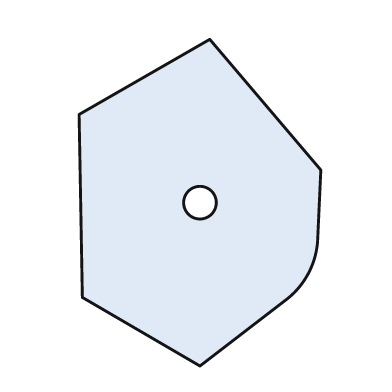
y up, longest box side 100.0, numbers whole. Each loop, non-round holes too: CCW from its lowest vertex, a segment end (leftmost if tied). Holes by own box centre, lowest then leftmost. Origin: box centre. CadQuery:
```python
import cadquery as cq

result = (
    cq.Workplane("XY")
    .moveTo(0.0, -50.0)
    .lineTo(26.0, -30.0)
    .threePointArc((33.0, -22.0), (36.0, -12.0))
    .lineTo(37.0, 10.0)
    .lineTo(3.0, 50.0)
    .lineTo(-37.0, 27.0)
    .lineTo(-36.0, -29.0)
    .close()
    .moveTo(0.0, 0.0)
    .circle(5.0)
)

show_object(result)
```